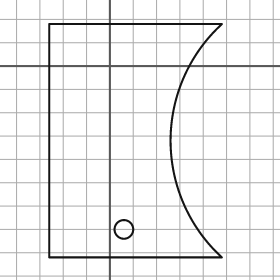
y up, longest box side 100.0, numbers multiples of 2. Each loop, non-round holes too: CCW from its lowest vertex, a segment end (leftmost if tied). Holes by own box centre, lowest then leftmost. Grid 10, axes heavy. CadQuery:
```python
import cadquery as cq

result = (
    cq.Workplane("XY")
    .moveTo(-26.0, -82.0)
    .lineTo(48.0, -82.0)
    .threePointArc((26.0, -32.0), (48.0, 18.0))
    .lineTo(-26.0, 18.0)
    .close()
    .moveTo(6.0, -70.0)
    .circle(4.0)
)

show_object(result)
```